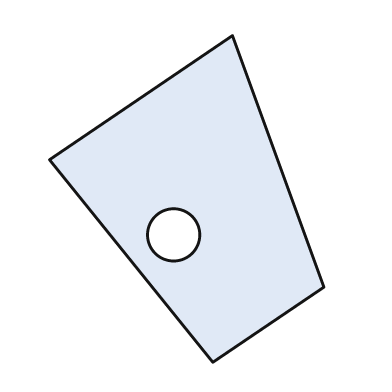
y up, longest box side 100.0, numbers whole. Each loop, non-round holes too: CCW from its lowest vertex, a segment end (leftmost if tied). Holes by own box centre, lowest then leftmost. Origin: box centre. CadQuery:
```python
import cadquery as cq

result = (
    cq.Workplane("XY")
    .moveTo(8.0, -50.0)
    .lineTo(42.0, -27.0)
    .lineTo(14.0, 50.0)
    .lineTo(-42.0, 12.0)
    .close()
    .moveTo(-4.0, -11.0)
    .circle(8.0)
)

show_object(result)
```